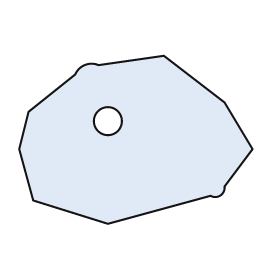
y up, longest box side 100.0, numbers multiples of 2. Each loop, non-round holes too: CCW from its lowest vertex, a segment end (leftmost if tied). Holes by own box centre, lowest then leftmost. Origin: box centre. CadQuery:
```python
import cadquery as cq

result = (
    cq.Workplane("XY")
    .moveTo(-12.0, -36.0)
    .lineTo(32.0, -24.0)
    .threePointArc((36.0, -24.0), (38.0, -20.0))
    .lineTo(50.0, -4.0)
    .lineTo(38.0, 16.0)
    .lineTo(12.0, 36.0)
    .lineTo(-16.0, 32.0)
    .threePointArc((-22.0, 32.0), (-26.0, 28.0))
    .lineTo(-46.0, 12.0)
    .lineTo(-50.0, -4.0)
    .lineTo(-44.0, -26.0)
    .close()
    .moveTo(-12.0, 8.0)
    .circle(6.0)
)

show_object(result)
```